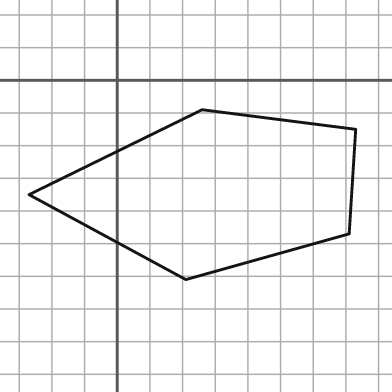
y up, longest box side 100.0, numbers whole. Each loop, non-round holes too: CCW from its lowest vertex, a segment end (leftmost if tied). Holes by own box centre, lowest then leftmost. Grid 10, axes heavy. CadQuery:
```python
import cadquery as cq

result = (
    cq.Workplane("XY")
    .moveTo(21.0, -61.0)
    .lineTo(71.0, -47.0)
    .lineTo(73.0, -15.0)
    .lineTo(26.0, -9.0)
    .lineTo(-27.0, -35.0)
    .close()
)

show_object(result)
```